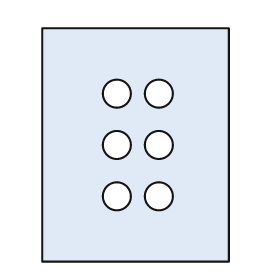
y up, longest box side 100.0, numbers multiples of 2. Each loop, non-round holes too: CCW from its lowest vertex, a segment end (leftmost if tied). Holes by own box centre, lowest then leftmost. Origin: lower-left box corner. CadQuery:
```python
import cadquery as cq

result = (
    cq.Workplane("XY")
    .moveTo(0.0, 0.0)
    .lineTo(80.0, 0.0)
    .lineTo(80.0, 100.0)
    .lineTo(0.0, 100.0)
    .close()
    .moveTo(32.0, 28.0)
    .circle(6.0)
    .moveTo(50.0, 28.0)
    .circle(6.0)
    .moveTo(32.0, 50.0)
    .circle(6.0)
    .moveTo(50.0, 50.0)
    .circle(6.0)
    .moveTo(32.0, 72.0)
    .circle(6.0)
    .moveTo(50.0, 72.0)
    .circle(6.0)
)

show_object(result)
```